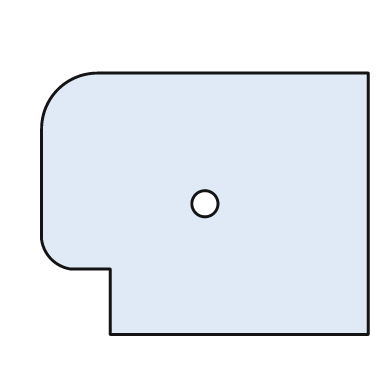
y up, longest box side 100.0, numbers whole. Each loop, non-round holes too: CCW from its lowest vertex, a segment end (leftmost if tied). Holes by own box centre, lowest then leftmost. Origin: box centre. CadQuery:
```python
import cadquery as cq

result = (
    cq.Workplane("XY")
    .moveTo(-29.0, -40.0)
    .lineTo(50.0, -40.0)
    .lineTo(50.0, 40.0)
    .lineTo(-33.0, 40.0)
    .threePointArc((-45.0, 35.0), (-50.0, 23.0))
    .lineTo(-50.0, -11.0)
    .threePointArc((-47.0, -17.0), (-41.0, -20.0))
    .lineTo(-29.0, -20.0)
    .close()
    .moveTo(0.0, 0.0)
    .circle(4.0)
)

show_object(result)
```